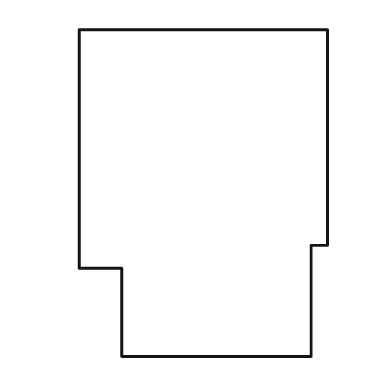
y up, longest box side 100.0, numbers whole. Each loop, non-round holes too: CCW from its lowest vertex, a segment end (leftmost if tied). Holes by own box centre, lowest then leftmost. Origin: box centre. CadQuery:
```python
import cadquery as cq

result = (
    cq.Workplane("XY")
    .moveTo(-25.0, -50.0)
    .lineTo(33.0, -50.0)
    .lineTo(33.0, -16.0)
    .lineTo(38.0, -16.0)
    .lineTo(38.0, 50.0)
    .lineTo(-38.0, 50.0)
    .lineTo(-38.0, -23.0)
    .lineTo(-25.0, -23.0)
    .close()
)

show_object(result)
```